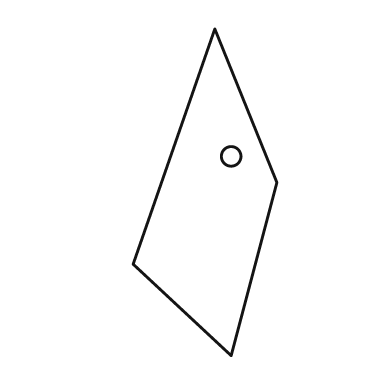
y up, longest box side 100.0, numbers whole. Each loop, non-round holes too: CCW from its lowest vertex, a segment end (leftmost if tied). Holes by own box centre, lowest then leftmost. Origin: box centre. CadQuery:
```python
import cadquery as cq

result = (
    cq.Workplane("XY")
    .moveTo(8.0, -50.0)
    .lineTo(22.0, 3.0)
    .lineTo(3.0, 50.0)
    .lineTo(-22.0, -22.0)
    .close()
    .moveTo(8.0, 11.0)
    .circle(3.0)
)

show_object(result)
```